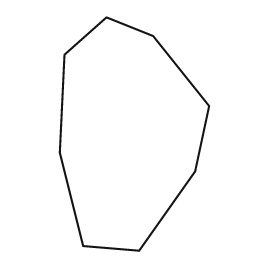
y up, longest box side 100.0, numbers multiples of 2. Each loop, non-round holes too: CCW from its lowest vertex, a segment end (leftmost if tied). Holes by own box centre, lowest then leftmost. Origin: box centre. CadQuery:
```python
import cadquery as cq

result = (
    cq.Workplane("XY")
    .moveTo(2.0, -50.0)
    .lineTo(26.0, -16.0)
    .lineTo(32.0, 12.0)
    .lineTo(8.0, 42.0)
    .lineTo(-12.0, 50.0)
    .lineTo(-30.0, 34.0)
    .lineTo(-32.0, -8.0)
    .lineTo(-22.0, -48.0)
    .close()
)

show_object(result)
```